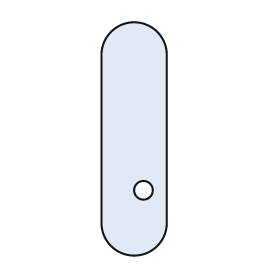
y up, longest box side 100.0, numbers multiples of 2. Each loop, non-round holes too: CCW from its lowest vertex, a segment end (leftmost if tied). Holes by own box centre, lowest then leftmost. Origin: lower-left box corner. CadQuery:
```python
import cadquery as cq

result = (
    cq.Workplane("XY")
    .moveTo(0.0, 14.0)
    .threePointArc((14.0, 0.0), (28.0, 14.0))
    .lineTo(28.0, 86.0)
    .threePointArc((14.0, 100.0), (0.0, 86.0))
    .close()
    .moveTo(18.0, 28.0)
    .circle(4.0)
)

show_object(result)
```